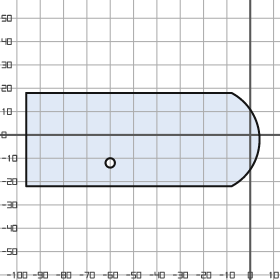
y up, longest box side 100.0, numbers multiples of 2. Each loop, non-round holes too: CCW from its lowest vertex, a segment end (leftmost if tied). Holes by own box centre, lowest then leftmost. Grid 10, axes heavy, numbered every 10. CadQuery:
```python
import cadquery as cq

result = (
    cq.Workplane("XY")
    .moveTo(-96.0, -22.0)
    .lineTo(-8.0, -22.0)
    .threePointArc((4.0, -2.0), (-8.0, 18.0))
    .lineTo(-96.0, 18.0)
    .close()
    .moveTo(-60.0, -12.0)
    .circle(2.0)
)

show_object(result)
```